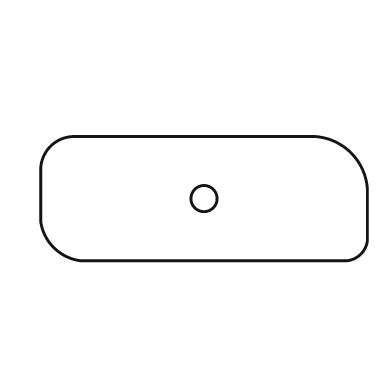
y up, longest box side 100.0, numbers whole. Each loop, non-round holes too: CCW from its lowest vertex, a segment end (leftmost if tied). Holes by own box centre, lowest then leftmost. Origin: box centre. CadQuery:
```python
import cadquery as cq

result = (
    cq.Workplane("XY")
    .moveTo(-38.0, -19.0)
    .lineTo(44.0, -19.0)
    .threePointArc((48.0, -17.0), (50.0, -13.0))
    .lineTo(50.0, 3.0)
    .threePointArc((45.0, 14.0), (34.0, 19.0))
    .lineTo(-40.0, 19.0)
    .threePointArc((-47.0, 16.0), (-50.0, 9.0))
    .lineTo(-50.0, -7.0)
    .threePointArc((-46.0, -15.0), (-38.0, -19.0))
    .close()
    .moveTo(0.0, 0.0)
    .circle(4.0)
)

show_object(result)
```